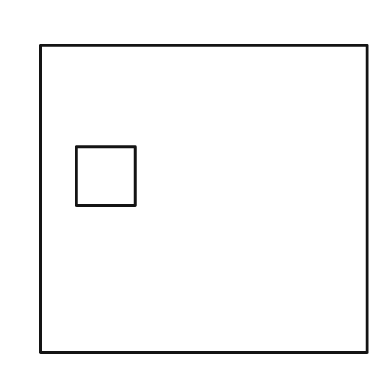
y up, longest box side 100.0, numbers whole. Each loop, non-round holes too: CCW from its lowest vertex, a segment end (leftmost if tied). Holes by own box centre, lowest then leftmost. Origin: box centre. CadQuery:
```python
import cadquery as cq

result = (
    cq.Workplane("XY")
    .moveTo(-50.0, -47.0)
    .lineTo(50.0, -47.0)
    .lineTo(50.0, 47.0)
    .lineTo(-50.0, 47.0)
    .close()
    .moveTo(-39.0, -2.0)
    .lineTo(-21.0, -2.0)
    .lineTo(-21.0, 16.0)
    .lineTo(-39.0, 16.0)
    .close()
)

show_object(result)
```